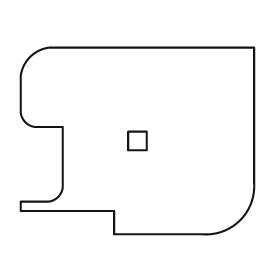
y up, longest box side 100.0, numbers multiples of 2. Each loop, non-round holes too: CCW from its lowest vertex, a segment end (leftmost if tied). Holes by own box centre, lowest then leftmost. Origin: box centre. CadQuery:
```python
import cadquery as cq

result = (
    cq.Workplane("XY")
    .moveTo(-10.0, -40.0)
    .lineTo(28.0, -40.0)
    .threePointArc((44.0, -34.0), (50.0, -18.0))
    .lineTo(50.0, 40.0)
    .lineTo(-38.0, 40.0)
    .threePointArc((-46.0, 36.0), (-50.0, 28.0))
    .lineTo(-50.0, 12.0)
    .threePointArc((-48.0, 8.0), (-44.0, 6.0))
    .lineTo(-32.0, 6.0)
    .lineTo(-32.0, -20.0)
    .threePointArc((-34.0, -24.0), (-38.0, -26.0))
    .lineTo(-50.0, -26.0)
    .lineTo(-50.0, -30.0)
    .lineTo(-10.0, -30.0)
    .close()
    .moveTo(-4.0, -4.0)
    .lineTo(4.0, -4.0)
    .lineTo(4.0, 4.0)
    .lineTo(-4.0, 4.0)
    .close()
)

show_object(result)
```